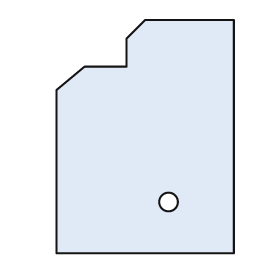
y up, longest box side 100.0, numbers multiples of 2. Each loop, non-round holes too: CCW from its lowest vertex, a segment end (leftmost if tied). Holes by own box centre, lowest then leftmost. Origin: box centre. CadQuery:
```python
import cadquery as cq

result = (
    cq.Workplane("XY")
    .moveTo(-38.0, -50.0)
    .lineTo(38.0, -50.0)
    .lineTo(38.0, 50.0)
    .lineTo(0.0, 50.0)
    .lineTo(-8.0, 42.0)
    .lineTo(-8.0, 30.0)
    .lineTo(-26.0, 30.0)
    .lineTo(-38.0, 20.0)
    .close()
    .moveTo(10.0, -28.0)
    .circle(4.0)
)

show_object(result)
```